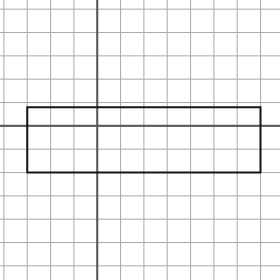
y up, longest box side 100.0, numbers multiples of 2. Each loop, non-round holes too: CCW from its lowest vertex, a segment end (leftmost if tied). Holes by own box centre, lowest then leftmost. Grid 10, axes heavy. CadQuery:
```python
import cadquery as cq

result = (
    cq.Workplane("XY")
    .moveTo(-30.0, -20.0)
    .lineTo(70.0, -20.0)
    .lineTo(70.0, 8.0)
    .lineTo(-30.0, 8.0)
    .close()
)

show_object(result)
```